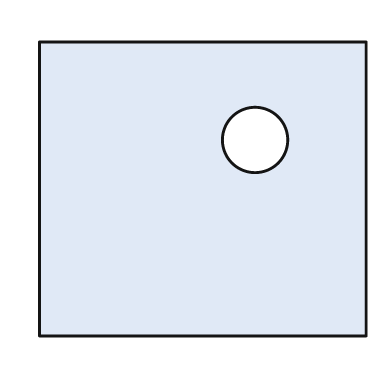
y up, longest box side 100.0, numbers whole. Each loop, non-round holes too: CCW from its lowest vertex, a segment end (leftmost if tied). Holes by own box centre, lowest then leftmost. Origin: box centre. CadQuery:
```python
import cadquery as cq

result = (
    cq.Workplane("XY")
    .moveTo(-50.0, -45.0)
    .lineTo(50.0, -45.0)
    .lineTo(50.0, 45.0)
    .lineTo(-50.0, 45.0)
    .close()
    .moveTo(16.0, 15.0)
    .circle(10.0)
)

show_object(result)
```